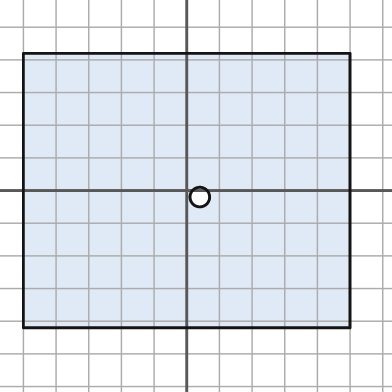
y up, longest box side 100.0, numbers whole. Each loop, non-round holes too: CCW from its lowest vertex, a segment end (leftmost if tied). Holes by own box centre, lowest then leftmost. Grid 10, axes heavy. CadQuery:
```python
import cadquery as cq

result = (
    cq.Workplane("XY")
    .moveTo(-50.0, -42.0)
    .lineTo(50.0, -42.0)
    .lineTo(50.0, 42.0)
    .lineTo(-50.0, 42.0)
    .close()
    .moveTo(4.0, -2.0)
    .circle(3.0)
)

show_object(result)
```